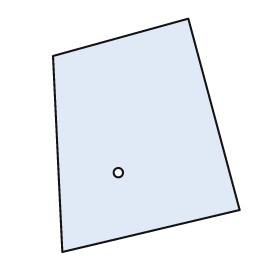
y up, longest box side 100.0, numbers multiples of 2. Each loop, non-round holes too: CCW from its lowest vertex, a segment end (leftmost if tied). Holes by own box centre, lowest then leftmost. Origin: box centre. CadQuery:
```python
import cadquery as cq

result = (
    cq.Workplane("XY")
    .moveTo(-36.0, -50.0)
    .lineTo(40.0, -32.0)
    .lineTo(18.0, 50.0)
    .lineTo(-40.0, 34.0)
    .close()
    .moveTo(-12.0, -16.0)
    .circle(2.0)
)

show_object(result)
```